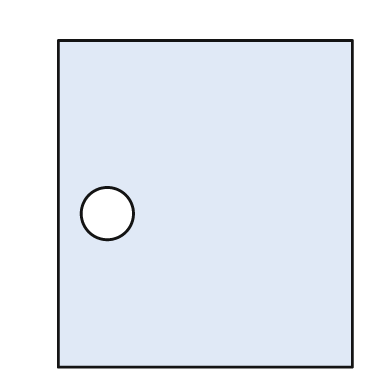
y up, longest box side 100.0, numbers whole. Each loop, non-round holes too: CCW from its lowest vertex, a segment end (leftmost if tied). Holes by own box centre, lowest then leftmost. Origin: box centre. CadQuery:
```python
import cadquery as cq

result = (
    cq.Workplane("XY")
    .moveTo(-45.0, -50.0)
    .lineTo(45.0, -50.0)
    .lineTo(45.0, 50.0)
    .lineTo(-45.0, 50.0)
    .close()
    .moveTo(-30.0, -3.0)
    .circle(8.0)
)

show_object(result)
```